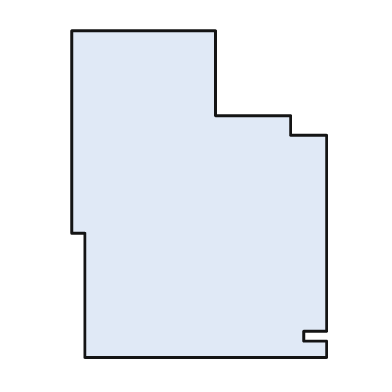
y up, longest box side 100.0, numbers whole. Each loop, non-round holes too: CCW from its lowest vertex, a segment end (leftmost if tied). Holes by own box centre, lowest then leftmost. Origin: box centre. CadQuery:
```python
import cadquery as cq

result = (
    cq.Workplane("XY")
    .moveTo(-35.0, -50.0)
    .lineTo(39.0, -50.0)
    .lineTo(39.0, -45.0)
    .lineTo(32.0, -45.0)
    .lineTo(32.0, -42.0)
    .lineTo(39.0, -42.0)
    .lineTo(39.0, 18.0)
    .lineTo(28.0, 18.0)
    .lineTo(28.0, 24.0)
    .lineTo(5.0, 24.0)
    .lineTo(5.0, 50.0)
    .lineTo(-39.0, 50.0)
    .lineTo(-39.0, -12.0)
    .lineTo(-35.0, -12.0)
    .close()
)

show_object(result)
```